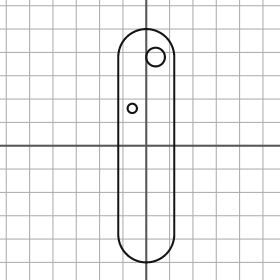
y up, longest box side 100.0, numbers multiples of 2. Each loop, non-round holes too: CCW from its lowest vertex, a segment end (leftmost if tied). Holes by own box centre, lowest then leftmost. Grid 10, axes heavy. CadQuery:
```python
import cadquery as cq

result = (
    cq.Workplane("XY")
    .moveTo(-12.0, -38.0)
    .threePointArc((0.0, -50.0), (12.0, -38.0))
    .lineTo(12.0, 38.0)
    .threePointArc((0.0, 50.0), (-12.0, 38.0))
    .close()
    .moveTo(-6.0, 16.0)
    .circle(2.0)
    .moveTo(4.0, 38.0)
    .circle(4.0)
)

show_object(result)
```